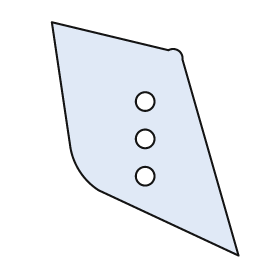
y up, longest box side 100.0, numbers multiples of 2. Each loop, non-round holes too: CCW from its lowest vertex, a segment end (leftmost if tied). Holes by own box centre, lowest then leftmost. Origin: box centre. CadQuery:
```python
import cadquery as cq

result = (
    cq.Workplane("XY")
    .moveTo(40.0, -50.0)
    .lineTo(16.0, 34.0)
    .threePointArc((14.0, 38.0), (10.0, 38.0))
    .lineTo(-40.0, 50.0)
    .lineTo(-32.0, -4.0)
    .threePointArc((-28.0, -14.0), (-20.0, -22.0))
    .close()
    .moveTo(0.0, -16.0)
    .circle(4.0)
    .moveTo(0.0, 0.0)
    .circle(4.0)
    .moveTo(0.0, 16.0)
    .circle(4.0)
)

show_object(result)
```